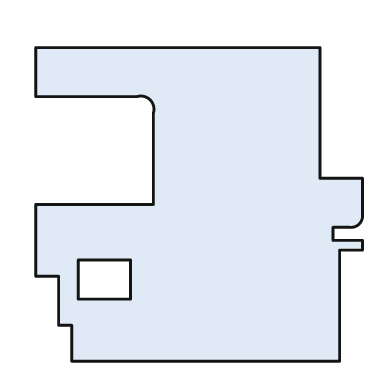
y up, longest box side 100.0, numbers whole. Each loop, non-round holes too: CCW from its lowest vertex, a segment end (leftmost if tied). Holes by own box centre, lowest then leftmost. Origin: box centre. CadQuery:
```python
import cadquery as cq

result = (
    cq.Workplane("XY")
    .moveTo(-39.0, -48.0)
    .lineTo(43.0, -48.0)
    .lineTo(43.0, -14.0)
    .lineTo(50.0, -14.0)
    .lineTo(50.0, -11.0)
    .lineTo(41.0, -11.0)
    .lineTo(41.0, -7.0)
    .lineTo(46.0, -7.0)
    .threePointArc((49.0, -6.0), (50.0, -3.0))
    .lineTo(50.0, 8.0)
    .lineTo(37.0, 8.0)
    .lineTo(37.0, 48.0)
    .lineTo(-50.0, 48.0)
    .lineTo(-50.0, 33.0)
    .lineTo(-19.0, 33.0)
    .threePointArc((-15.0, 32.0), (-14.0, 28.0))
    .lineTo(-14.0, 0.0)
    .lineTo(-50.0, 0.0)
    .lineTo(-50.0, -22.0)
    .lineTo(-43.0, -22.0)
    .lineTo(-43.0, -37.0)
    .lineTo(-39.0, -37.0)
    .close()
    .moveTo(-37.0, -29.0)
    .lineTo(-21.0, -29.0)
    .lineTo(-21.0, -17.0)
    .lineTo(-37.0, -17.0)
    .close()
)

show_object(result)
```